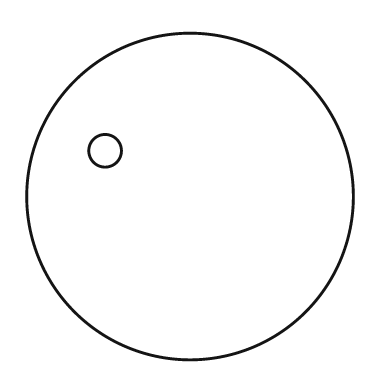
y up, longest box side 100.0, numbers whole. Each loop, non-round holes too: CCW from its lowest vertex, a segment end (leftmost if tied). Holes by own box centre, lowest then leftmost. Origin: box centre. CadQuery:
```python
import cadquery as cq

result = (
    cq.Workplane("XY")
    .moveTo(0.0, 0.0)
    .circle(50.0)
    .moveTo(-26.0, 14.0)
    .circle(5.0)
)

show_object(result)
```